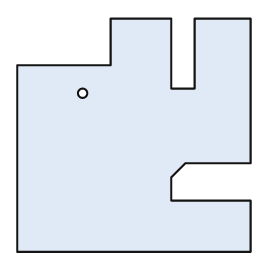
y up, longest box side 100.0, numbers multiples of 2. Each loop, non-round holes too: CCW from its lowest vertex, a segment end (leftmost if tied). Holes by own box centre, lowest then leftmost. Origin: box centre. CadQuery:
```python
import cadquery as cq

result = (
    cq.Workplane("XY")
    .moveTo(-50.0, -50.0)
    .lineTo(50.0, -50.0)
    .lineTo(50.0, -28.0)
    .lineTo(16.0, -28.0)
    .lineTo(16.0, -18.0)
    .lineTo(22.0, -12.0)
    .lineTo(50.0, -12.0)
    .lineTo(50.0, 50.0)
    .lineTo(26.0, 50.0)
    .lineTo(26.0, 20.0)
    .lineTo(16.0, 20.0)
    .lineTo(16.0, 50.0)
    .lineTo(-10.0, 50.0)
    .lineTo(-10.0, 30.0)
    .lineTo(-50.0, 30.0)
    .close()
    .moveTo(-22.0, 18.0)
    .circle(2.0)
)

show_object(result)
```